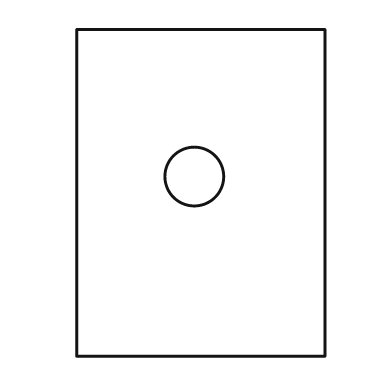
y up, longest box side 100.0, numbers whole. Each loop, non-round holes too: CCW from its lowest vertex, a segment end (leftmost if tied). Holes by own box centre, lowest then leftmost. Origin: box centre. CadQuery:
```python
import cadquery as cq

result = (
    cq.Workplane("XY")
    .moveTo(-38.0, -50.0)
    .lineTo(38.0, -50.0)
    .lineTo(38.0, 50.0)
    .lineTo(-38.0, 50.0)
    .close()
    .moveTo(-2.0, 5.0)
    .circle(9.0)
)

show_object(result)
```